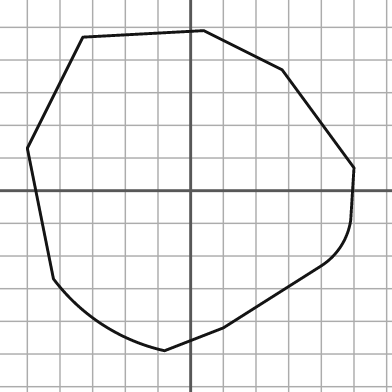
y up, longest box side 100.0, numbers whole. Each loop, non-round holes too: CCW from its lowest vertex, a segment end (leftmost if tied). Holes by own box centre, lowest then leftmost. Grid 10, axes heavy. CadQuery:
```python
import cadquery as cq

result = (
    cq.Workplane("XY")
    .moveTo(-8.0, -49.0)
    .lineTo(10.0, -42.0)
    .lineTo(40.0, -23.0)
    .threePointArc((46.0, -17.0), (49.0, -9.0))
    .lineTo(50.0, 7.0)
    .lineTo(28.0, 37.0)
    .lineTo(4.0, 49.0)
    .lineTo(-33.0, 47.0)
    .lineTo(-50.0, 13.0)
    .lineTo(-42.0, -27.0)
    .threePointArc((-27.0, -41.0), (-8.0, -49.0))
    .close()
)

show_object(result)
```